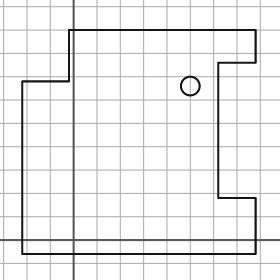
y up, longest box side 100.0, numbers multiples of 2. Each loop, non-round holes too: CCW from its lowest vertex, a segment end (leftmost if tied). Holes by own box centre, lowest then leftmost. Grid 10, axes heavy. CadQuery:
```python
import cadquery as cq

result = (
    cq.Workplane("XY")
    .moveTo(-22.0, -6.0)
    .lineTo(78.0, -6.0)
    .lineTo(78.0, 18.0)
    .lineTo(62.0, 18.0)
    .lineTo(62.0, 76.0)
    .lineTo(78.0, 76.0)
    .lineTo(78.0, 90.0)
    .lineTo(-2.0, 90.0)
    .lineTo(-2.0, 68.0)
    .lineTo(-22.0, 68.0)
    .close()
    .moveTo(50.0, 66.0)
    .circle(4.0)
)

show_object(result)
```